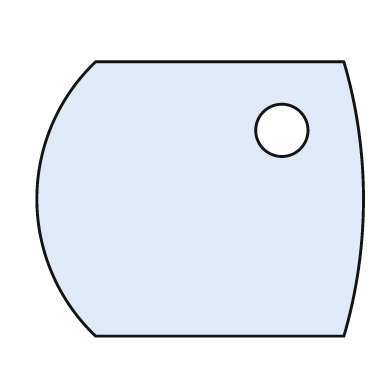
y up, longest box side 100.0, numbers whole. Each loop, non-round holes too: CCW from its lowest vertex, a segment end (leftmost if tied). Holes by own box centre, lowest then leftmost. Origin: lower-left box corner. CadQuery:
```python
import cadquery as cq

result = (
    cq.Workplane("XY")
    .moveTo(18.0, 0.0)
    .lineTo(94.0, 0.0)
    .threePointArc((100.0, 42.0), (94.0, 84.0))
    .lineTo(18.0, 84.0)
    .threePointArc((0.0, 42.0), (18.0, 0.0))
    .close()
    .moveTo(75.0, 63.0)
    .circle(8.0)
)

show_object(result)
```